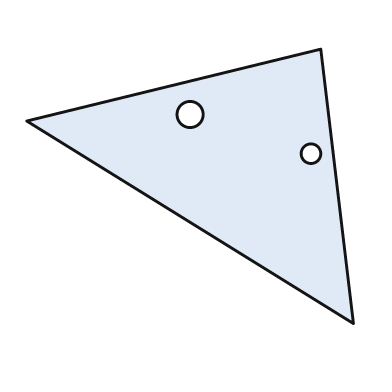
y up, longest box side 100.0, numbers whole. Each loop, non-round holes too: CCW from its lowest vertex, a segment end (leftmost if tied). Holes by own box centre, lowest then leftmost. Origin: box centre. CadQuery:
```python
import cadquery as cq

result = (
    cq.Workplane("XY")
    .moveTo(50.0, -42.0)
    .lineTo(40.0, 42.0)
    .lineTo(-50.0, 20.0)
    .close()
    .moveTo(37.0, 10.0)
    .circle(3.0)
    .moveTo(0.0, 22.0)
    .circle(4.0)
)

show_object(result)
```